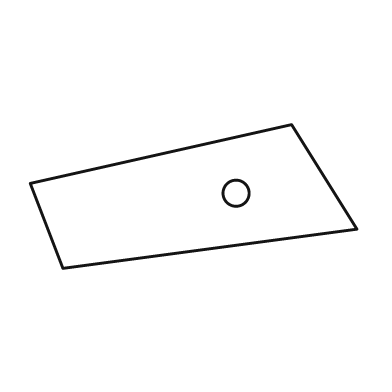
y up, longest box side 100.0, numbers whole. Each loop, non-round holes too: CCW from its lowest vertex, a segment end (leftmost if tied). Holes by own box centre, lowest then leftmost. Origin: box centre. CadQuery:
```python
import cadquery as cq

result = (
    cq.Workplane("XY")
    .moveTo(-40.0, -22.0)
    .lineTo(50.0, -10.0)
    .lineTo(30.0, 22.0)
    .lineTo(-50.0, 4.0)
    .close()
    .moveTo(13.0, 1.0)
    .circle(4.0)
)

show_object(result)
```